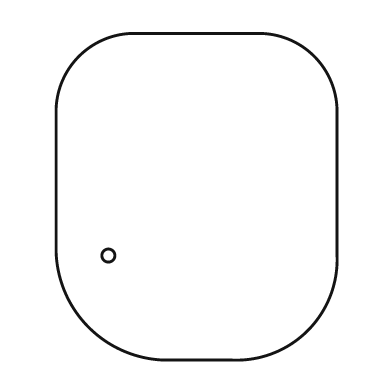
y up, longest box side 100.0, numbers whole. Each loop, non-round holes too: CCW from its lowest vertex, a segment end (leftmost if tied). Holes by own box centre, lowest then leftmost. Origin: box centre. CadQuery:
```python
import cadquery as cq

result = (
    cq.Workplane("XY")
    .moveTo(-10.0, -50.0)
    .lineTo(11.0, -50.0)
    .threePointArc((34.0, -41.0), (43.0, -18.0))
    .lineTo(43.0, 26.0)
    .threePointArc((36.0, 43.0), (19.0, 50.0))
    .lineTo(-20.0, 50.0)
    .threePointArc((-36.0, 43.0), (-43.0, 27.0))
    .lineTo(-43.0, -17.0)
    .threePointArc((-33.0, -40.0), (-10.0, -50.0))
    .close()
    .moveTo(-27.0, -18.0)
    .circle(2.0)
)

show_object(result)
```